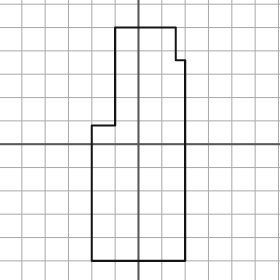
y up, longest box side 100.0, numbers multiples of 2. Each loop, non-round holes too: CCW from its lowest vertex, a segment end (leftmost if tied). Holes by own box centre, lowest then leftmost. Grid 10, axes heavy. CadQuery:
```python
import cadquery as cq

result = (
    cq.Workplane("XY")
    .moveTo(-20.0, -50.0)
    .lineTo(20.0, -50.0)
    .lineTo(20.0, 36.0)
    .lineTo(16.0, 36.0)
    .lineTo(16.0, 50.0)
    .lineTo(-10.0, 50.0)
    .lineTo(-10.0, 8.0)
    .lineTo(-20.0, 8.0)
    .close()
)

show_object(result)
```